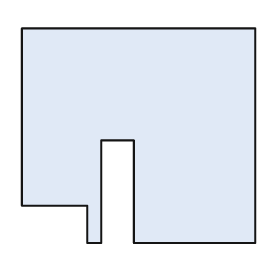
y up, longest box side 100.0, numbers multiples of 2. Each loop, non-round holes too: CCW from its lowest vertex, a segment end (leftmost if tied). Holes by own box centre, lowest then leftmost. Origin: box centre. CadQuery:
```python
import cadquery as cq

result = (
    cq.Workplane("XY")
    .moveTo(-22.0, -46.0)
    .lineTo(-16.0, -46.0)
    .lineTo(-16.0, -2.0)
    .lineTo(-2.0, -2.0)
    .lineTo(-2.0, -46.0)
    .lineTo(50.0, -46.0)
    .lineTo(50.0, 46.0)
    .lineTo(-50.0, 46.0)
    .lineTo(-50.0, -30.0)
    .lineTo(-22.0, -30.0)
    .close()
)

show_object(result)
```